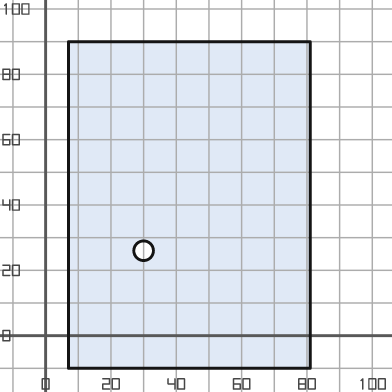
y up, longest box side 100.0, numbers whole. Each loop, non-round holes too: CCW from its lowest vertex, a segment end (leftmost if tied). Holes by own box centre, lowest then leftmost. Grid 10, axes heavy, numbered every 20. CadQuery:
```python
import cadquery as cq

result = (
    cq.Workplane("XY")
    .moveTo(7.0, -10.0)
    .lineTo(81.0, -10.0)
    .lineTo(81.0, 90.0)
    .lineTo(7.0, 90.0)
    .close()
    .moveTo(30.0, 26.0)
    .circle(3.0)
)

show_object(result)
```